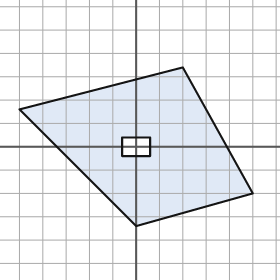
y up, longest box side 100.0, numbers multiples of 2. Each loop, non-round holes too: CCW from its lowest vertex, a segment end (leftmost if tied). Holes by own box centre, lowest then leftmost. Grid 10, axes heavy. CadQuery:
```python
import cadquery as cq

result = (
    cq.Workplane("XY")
    .moveTo(0.0, -34.0)
    .lineTo(50.0, -20.0)
    .lineTo(20.0, 34.0)
    .lineTo(-50.0, 16.0)
    .close()
    .moveTo(-6.0, -4.0)
    .lineTo(6.0, -4.0)
    .lineTo(6.0, 4.0)
    .lineTo(-6.0, 4.0)
    .close()
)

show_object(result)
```